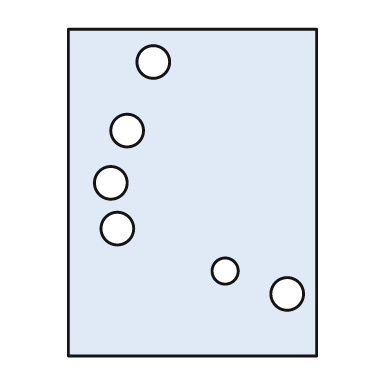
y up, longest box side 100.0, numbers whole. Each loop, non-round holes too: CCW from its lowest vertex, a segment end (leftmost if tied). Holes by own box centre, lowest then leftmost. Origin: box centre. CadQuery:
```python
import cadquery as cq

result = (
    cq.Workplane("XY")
    .moveTo(-38.0, -50.0)
    .lineTo(38.0, -50.0)
    .lineTo(38.0, 50.0)
    .lineTo(-38.0, 50.0)
    .close()
    .moveTo(29.0, -31.0)
    .circle(5.0)
    .moveTo(10.0, -24.0)
    .circle(4.0)
    .moveTo(-23.0, -11.0)
    .circle(5.0)
    .moveTo(-25.0, 3.0)
    .circle(5.0)
    .moveTo(-20.0, 19.0)
    .circle(5.0)
    .moveTo(-12.0, 40.0)
    .circle(5.0)
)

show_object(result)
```